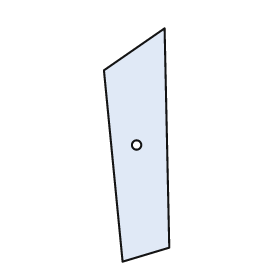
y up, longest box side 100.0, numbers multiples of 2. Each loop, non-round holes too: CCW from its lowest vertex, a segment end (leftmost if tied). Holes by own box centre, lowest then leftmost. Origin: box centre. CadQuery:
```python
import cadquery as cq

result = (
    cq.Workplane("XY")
    .moveTo(-6.0, -50.0)
    .lineTo(14.0, -44.0)
    .lineTo(12.0, 50.0)
    .lineTo(-14.0, 32.0)
    .close()
    .moveTo(0.0, 0.0)
    .circle(2.0)
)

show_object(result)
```